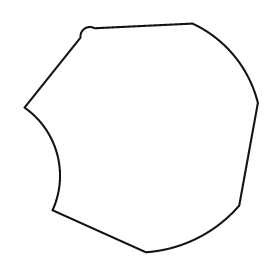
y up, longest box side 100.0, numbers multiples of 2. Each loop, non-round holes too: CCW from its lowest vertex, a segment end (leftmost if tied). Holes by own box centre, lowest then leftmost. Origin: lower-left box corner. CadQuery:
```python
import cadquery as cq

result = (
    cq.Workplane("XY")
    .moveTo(52.0, 0.0)
    .threePointArc((74.0, 6.0), (92.0, 20.0))
    .lineTo(100.0, 64.0)
    .threePointArc((90.0, 84.0), (72.0, 98.0))
    .lineTo(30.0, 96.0)
    .threePointArc((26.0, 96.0), (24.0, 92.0))
    .lineTo(0.0, 62.0)
    .threePointArc((14.0, 42.0), (12.0, 18.0))
    .close()
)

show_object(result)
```